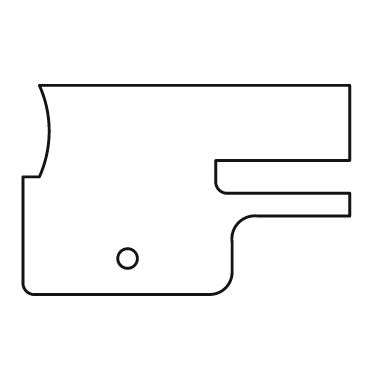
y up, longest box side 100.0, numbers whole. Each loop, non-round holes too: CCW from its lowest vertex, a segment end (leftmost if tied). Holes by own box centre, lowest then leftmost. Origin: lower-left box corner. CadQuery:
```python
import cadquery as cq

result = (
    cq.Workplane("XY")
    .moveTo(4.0, 0.0)
    .lineTo(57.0, 0.0)
    .threePointArc((62.0, 2.0), (64.0, 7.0))
    .lineTo(64.0, 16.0)
    .threePointArc((66.0, 22.0), (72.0, 24.0))
    .lineTo(100.0, 24.0)
    .lineTo(100.0, 31.0)
    .lineTo(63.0, 31.0)
    .threePointArc((60.0, 32.0), (59.0, 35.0))
    .lineTo(59.0, 41.0)
    .lineTo(100.0, 41.0)
    .lineTo(100.0, 64.0)
    .lineTo(5.0, 64.0)
    .threePointArc((8.0, 50.0), (5.0, 36.0))
    .lineTo(0.0, 36.0)
    .lineTo(0.0, 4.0)
    .threePointArc((1.0, 1.0), (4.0, 0.0))
    .close()
    .moveTo(32.0, 11.0)
    .circle(3.0)
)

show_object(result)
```